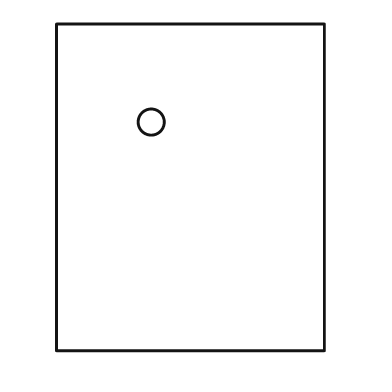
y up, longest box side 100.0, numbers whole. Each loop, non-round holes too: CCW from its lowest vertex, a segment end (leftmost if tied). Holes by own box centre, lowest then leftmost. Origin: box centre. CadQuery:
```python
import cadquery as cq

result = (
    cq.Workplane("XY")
    .moveTo(-41.0, -50.0)
    .lineTo(41.0, -50.0)
    .lineTo(41.0, 50.0)
    .lineTo(-41.0, 50.0)
    .close()
    .moveTo(-12.0, 20.0)
    .circle(4.0)
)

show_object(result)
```